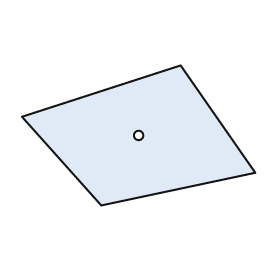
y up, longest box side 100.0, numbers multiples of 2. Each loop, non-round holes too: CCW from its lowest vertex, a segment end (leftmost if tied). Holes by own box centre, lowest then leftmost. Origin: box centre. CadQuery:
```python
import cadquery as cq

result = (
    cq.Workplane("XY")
    .moveTo(-16.0, -30.0)
    .lineTo(50.0, -16.0)
    .lineTo(18.0, 30.0)
    .lineTo(-50.0, 8.0)
    .close()
    .moveTo(0.0, 0.0)
    .circle(2.0)
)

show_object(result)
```